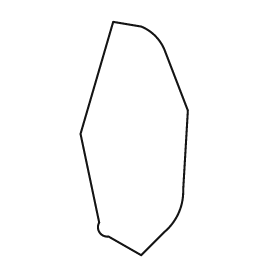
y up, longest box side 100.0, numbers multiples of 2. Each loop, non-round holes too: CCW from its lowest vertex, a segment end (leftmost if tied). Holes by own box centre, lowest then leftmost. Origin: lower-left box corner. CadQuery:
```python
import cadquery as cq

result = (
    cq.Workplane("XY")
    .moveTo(26.0, 0.0)
    .lineTo(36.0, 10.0)
    .threePointArc((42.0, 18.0), (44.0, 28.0))
    .lineTo(46.0, 62.0)
    .lineTo(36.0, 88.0)
    .threePointArc((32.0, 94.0), (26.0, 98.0))
    .lineTo(14.0, 100.0)
    .lineTo(0.0, 52.0)
    .lineTo(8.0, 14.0)
    .threePointArc((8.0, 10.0), (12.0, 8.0))
    .close()
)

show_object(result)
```